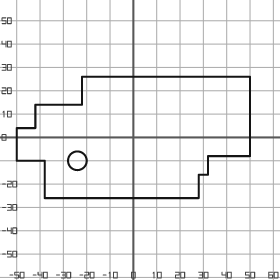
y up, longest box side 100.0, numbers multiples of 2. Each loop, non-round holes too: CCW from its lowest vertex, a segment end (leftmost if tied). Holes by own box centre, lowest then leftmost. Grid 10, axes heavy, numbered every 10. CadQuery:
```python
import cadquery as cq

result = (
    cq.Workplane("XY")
    .moveTo(-38.0, -26.0)
    .lineTo(28.0, -26.0)
    .lineTo(28.0, -16.0)
    .lineTo(32.0, -16.0)
    .lineTo(32.0, -8.0)
    .lineTo(50.0, -8.0)
    .lineTo(50.0, 26.0)
    .lineTo(-22.0, 26.0)
    .lineTo(-22.0, 14.0)
    .lineTo(-42.0, 14.0)
    .lineTo(-42.0, 4.0)
    .lineTo(-50.0, 4.0)
    .lineTo(-50.0, -10.0)
    .lineTo(-38.0, -10.0)
    .close()
    .moveTo(-24.0, -10.0)
    .circle(4.0)
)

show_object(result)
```